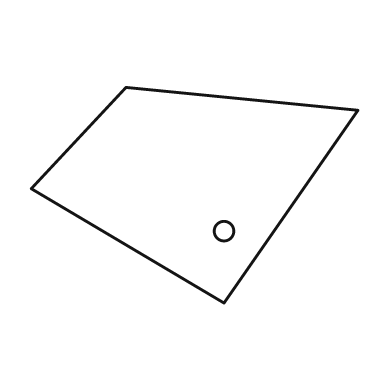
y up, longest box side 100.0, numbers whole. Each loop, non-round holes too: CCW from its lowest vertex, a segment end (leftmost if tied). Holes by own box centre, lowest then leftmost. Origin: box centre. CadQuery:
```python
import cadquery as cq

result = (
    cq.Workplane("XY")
    .moveTo(9.0, -33.0)
    .lineTo(50.0, 26.0)
    .lineTo(-21.0, 33.0)
    .lineTo(-50.0, 2.0)
    .close()
    .moveTo(9.0, -11.0)
    .circle(3.0)
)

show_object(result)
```